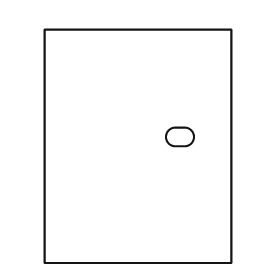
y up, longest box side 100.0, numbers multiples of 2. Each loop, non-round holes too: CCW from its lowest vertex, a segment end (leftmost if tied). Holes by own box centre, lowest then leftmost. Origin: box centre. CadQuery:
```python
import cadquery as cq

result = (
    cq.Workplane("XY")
    .moveTo(-40.0, -50.0)
    .lineTo(40.0, -50.0)
    .lineTo(40.0, 50.0)
    .lineTo(-40.0, 50.0)
    .close()
    .moveTo(16.0, 0.0)
    .lineTo(20.0, 0.0)
    .threePointArc((24.0, 4.0), (20.0, 8.0))
    .lineTo(16.0, 8.0)
    .threePointArc((12.0, 4.0), (16.0, 0.0))
    .close()
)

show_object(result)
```